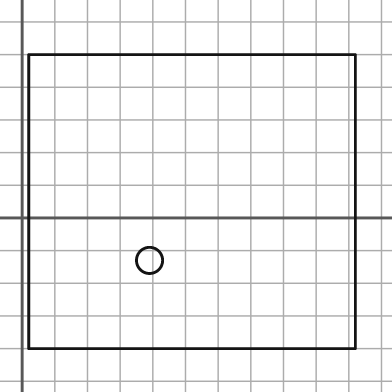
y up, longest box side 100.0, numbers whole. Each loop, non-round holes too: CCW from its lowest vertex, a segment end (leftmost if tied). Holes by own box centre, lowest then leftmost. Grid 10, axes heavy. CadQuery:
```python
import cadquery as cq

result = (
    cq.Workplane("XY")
    .moveTo(2.0, -40.0)
    .lineTo(102.0, -40.0)
    .lineTo(102.0, 50.0)
    .lineTo(2.0, 50.0)
    .close()
    .moveTo(39.0, -13.0)
    .circle(4.0)
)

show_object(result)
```